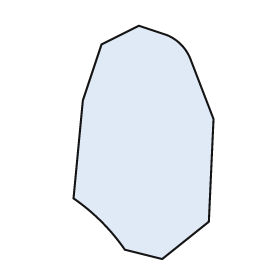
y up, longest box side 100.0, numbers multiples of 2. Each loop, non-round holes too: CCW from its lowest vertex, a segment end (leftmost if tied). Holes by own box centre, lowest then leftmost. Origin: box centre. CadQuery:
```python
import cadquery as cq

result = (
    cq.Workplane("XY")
    .moveTo(8.0, -50.0)
    .lineTo(28.0, -34.0)
    .lineTo(30.0, 10.0)
    .lineTo(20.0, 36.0)
    .threePointArc((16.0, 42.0), (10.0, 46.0))
    .lineTo(-2.0, 50.0)
    .lineTo(-18.0, 42.0)
    .lineTo(-26.0, 18.0)
    .lineTo(-30.0, -24.0)
    .threePointArc((-18.0, -34.0), (-8.0, -46.0))
    .close()
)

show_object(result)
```